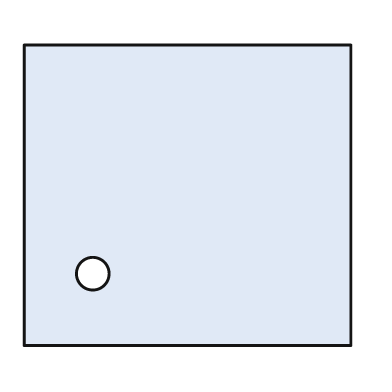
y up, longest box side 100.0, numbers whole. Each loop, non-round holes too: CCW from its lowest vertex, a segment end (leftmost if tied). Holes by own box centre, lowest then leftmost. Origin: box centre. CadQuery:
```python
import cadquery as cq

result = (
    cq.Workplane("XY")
    .moveTo(-50.0, -46.0)
    .lineTo(50.0, -46.0)
    .lineTo(50.0, 46.0)
    .lineTo(-50.0, 46.0)
    .close()
    .moveTo(-29.0, -24.0)
    .circle(5.0)
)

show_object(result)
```